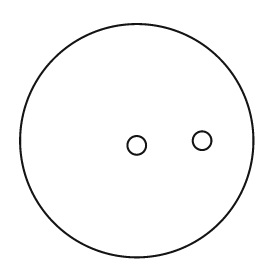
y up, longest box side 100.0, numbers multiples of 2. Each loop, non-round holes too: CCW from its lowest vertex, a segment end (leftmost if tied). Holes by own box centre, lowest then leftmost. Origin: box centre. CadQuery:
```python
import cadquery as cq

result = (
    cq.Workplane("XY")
    .moveTo(0.0, 0.0)
    .circle(50.0)
    .moveTo(0.0, -2.0)
    .circle(4.0)
    .moveTo(28.0, 0.0)
    .circle(4.0)
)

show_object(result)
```